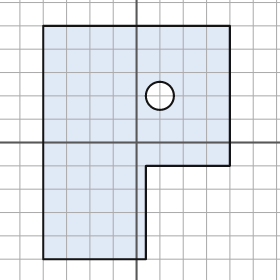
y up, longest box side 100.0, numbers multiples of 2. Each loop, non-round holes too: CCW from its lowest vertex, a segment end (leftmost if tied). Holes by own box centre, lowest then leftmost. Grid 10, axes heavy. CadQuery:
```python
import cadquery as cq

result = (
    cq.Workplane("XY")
    .moveTo(-40.0, -50.0)
    .lineTo(4.0, -50.0)
    .lineTo(4.0, -10.0)
    .lineTo(40.0, -10.0)
    .lineTo(40.0, 50.0)
    .lineTo(-40.0, 50.0)
    .close()
    .moveTo(10.0, 20.0)
    .circle(6.0)
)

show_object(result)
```